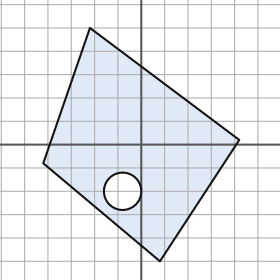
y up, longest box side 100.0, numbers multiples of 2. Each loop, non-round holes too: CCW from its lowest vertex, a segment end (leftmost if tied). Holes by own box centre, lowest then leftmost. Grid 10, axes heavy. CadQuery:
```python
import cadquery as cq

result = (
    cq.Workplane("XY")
    .moveTo(8.0, -50.0)
    .lineTo(42.0, 2.0)
    .lineTo(-22.0, 50.0)
    .lineTo(-42.0, -8.0)
    .close()
    .moveTo(-8.0, -20.0)
    .circle(8.0)
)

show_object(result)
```